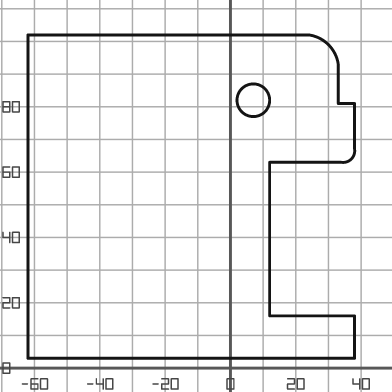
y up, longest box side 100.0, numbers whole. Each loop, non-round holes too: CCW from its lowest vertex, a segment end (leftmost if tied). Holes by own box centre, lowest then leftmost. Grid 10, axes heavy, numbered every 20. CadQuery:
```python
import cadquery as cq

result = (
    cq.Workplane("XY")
    .moveTo(-62.0, 3.0)
    .lineTo(38.0, 3.0)
    .lineTo(38.0, 16.0)
    .lineTo(12.0, 16.0)
    .lineTo(12.0, 63.0)
    .lineTo(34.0, 63.0)
    .threePointArc((37.0, 64.0), (38.0, 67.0))
    .lineTo(38.0, 81.0)
    .lineTo(33.0, 81.0)
    .lineTo(33.0, 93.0)
    .threePointArc((30.0, 99.0), (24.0, 102.0))
    .lineTo(-62.0, 102.0)
    .close()
    .moveTo(7.0, 82.0)
    .circle(5.0)
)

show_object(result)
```